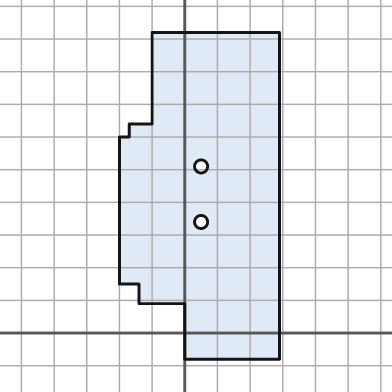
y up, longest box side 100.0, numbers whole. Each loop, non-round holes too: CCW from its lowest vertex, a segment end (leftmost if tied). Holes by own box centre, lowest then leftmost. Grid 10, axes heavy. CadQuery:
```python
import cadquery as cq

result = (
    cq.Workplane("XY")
    .moveTo(0.0, -8.0)
    .lineTo(29.0, -8.0)
    .lineTo(29.0, 92.0)
    .lineTo(-10.0, 92.0)
    .lineTo(-10.0, 64.0)
    .lineTo(-17.0, 64.0)
    .lineTo(-17.0, 60.0)
    .lineTo(-20.0, 60.0)
    .lineTo(-20.0, 15.0)
    .lineTo(-14.0, 15.0)
    .lineTo(-14.0, 9.0)
    .lineTo(0.0, 9.0)
    .close()
    .moveTo(5.0, 34.0)
    .circle(2.0)
    .moveTo(5.0, 51.0)
    .circle(2.0)
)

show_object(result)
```